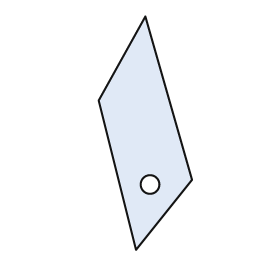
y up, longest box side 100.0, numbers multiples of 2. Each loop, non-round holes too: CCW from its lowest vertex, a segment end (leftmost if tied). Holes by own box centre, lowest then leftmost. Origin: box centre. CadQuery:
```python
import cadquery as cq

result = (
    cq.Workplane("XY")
    .moveTo(-4.0, -50.0)
    .lineTo(20.0, -20.0)
    .lineTo(0.0, 50.0)
    .lineTo(-20.0, 14.0)
    .close()
    .moveTo(2.0, -22.0)
    .circle(4.0)
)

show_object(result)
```